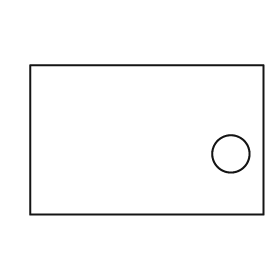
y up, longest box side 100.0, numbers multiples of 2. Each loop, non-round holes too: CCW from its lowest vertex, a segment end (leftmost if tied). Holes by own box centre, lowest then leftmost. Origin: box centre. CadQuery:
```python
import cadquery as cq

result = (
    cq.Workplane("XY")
    .moveTo(-50.0, -32.0)
    .lineTo(50.0, -32.0)
    .lineTo(50.0, 32.0)
    .lineTo(-50.0, 32.0)
    .close()
    .moveTo(36.0, -6.0)
    .circle(8.0)
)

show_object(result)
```